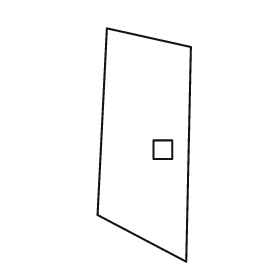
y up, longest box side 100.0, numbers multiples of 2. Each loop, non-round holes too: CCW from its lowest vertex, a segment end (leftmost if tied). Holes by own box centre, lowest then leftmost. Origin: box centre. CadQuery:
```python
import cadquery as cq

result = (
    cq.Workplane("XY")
    .moveTo(18.0, -50.0)
    .lineTo(20.0, 42.0)
    .lineTo(-16.0, 50.0)
    .lineTo(-20.0, -30.0)
    .close()
    .moveTo(4.0, -6.0)
    .lineTo(12.0, -6.0)
    .lineTo(12.0, 2.0)
    .lineTo(4.0, 2.0)
    .close()
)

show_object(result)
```